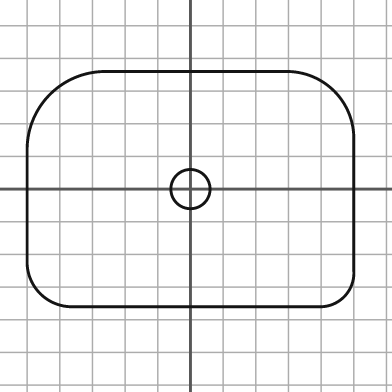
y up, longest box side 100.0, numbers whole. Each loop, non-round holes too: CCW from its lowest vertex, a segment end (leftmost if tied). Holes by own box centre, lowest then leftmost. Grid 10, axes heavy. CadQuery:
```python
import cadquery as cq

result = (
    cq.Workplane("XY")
    .moveTo(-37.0, -36.0)
    .lineTo(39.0, -36.0)
    .threePointArc((47.0, -33.0), (50.0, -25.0))
    .lineTo(50.0, 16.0)
    .threePointArc((44.0, 30.0), (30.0, 36.0))
    .lineTo(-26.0, 36.0)
    .threePointArc((-43.0, 29.0), (-50.0, 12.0))
    .lineTo(-50.0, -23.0)
    .threePointArc((-46.0, -32.0), (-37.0, -36.0))
    .close()
    .moveTo(0.0, 0.0)
    .circle(6.0)
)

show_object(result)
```